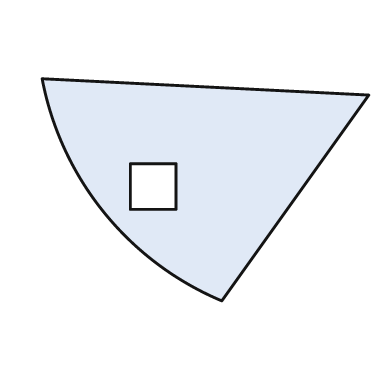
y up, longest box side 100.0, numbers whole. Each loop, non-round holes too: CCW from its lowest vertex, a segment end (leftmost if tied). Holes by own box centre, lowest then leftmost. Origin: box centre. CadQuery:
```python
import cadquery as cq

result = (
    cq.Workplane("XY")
    .moveTo(5.0, -34.0)
    .lineTo(50.0, 29.0)
    .lineTo(-50.0, 34.0)
    .threePointArc((-31.0, -7.0), (5.0, -34.0))
    .close()
    .moveTo(-23.0, -6.0)
    .lineTo(-9.0, -6.0)
    .lineTo(-9.0, 8.0)
    .lineTo(-23.0, 8.0)
    .close()
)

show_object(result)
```